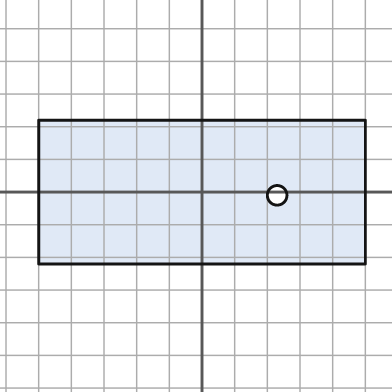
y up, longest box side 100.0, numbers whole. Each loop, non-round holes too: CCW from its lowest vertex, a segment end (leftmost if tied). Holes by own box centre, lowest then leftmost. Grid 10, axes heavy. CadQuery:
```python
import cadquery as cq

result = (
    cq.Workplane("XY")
    .moveTo(-50.0, -22.0)
    .lineTo(50.0, -22.0)
    .lineTo(50.0, 22.0)
    .lineTo(-50.0, 22.0)
    .close()
    .moveTo(23.0, -1.0)
    .circle(3.0)
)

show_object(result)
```